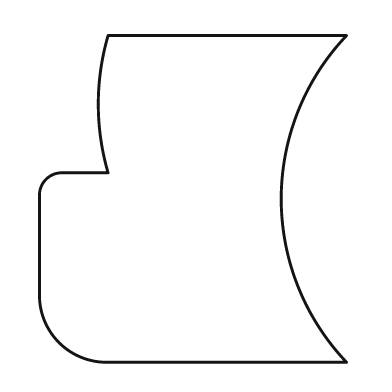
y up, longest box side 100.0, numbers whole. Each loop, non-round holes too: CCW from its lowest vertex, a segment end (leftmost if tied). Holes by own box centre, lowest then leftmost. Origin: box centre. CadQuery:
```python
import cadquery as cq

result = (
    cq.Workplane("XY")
    .moveTo(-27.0, -50.0)
    .lineTo(47.0, -50.0)
    .threePointArc((27.0, 0.0), (47.0, 50.0))
    .lineTo(-26.0, 50.0)
    .threePointArc((-29.0, 29.0), (-26.0, 8.0))
    .lineTo(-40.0, 8.0)
    .threePointArc((-45.0, 6.0), (-47.0, 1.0))
    .lineTo(-47.0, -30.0)
    .threePointArc((-41.0, -44.0), (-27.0, -50.0))
    .close()
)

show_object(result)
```